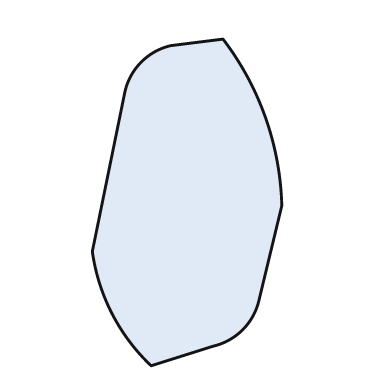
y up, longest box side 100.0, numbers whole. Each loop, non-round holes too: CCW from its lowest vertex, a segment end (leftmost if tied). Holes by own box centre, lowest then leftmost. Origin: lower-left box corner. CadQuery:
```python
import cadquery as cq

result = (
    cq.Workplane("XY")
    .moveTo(18.0, 0.0)
    .lineTo(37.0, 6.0)
    .threePointArc((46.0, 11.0), (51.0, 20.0))
    .lineTo(58.0, 49.0)
    .threePointArc((53.0, 76.0), (40.0, 100.0))
    .lineTo(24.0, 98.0)
    .threePointArc((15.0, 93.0), (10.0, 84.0))
    .lineTo(0.0, 35.0)
    .threePointArc((6.0, 16.0), (18.0, 0.0))
    .close()
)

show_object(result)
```